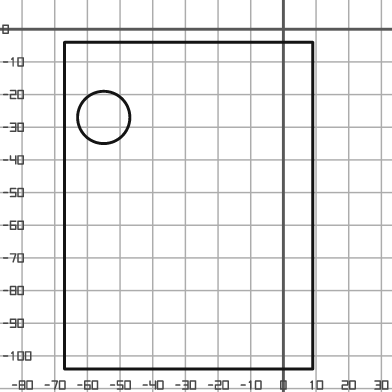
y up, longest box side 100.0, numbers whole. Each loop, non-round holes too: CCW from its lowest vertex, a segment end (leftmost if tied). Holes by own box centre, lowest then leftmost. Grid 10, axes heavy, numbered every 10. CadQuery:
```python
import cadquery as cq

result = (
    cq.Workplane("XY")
    .moveTo(-67.0, -104.0)
    .lineTo(9.0, -104.0)
    .lineTo(9.0, -4.0)
    .lineTo(-67.0, -4.0)
    .close()
    .moveTo(-55.0, -27.0)
    .circle(8.0)
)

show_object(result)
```